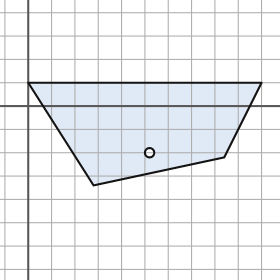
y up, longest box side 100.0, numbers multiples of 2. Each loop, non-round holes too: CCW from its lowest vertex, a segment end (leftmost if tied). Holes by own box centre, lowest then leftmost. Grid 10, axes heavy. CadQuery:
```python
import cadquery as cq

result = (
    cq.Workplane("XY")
    .moveTo(28.0, -34.0)
    .lineTo(84.0, -22.0)
    .lineTo(100.0, 10.0)
    .lineTo(0.0, 10.0)
    .close()
    .moveTo(52.0, -20.0)
    .circle(2.0)
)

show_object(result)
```